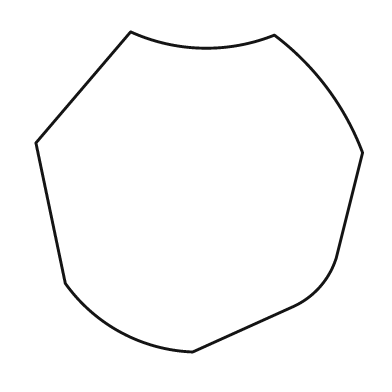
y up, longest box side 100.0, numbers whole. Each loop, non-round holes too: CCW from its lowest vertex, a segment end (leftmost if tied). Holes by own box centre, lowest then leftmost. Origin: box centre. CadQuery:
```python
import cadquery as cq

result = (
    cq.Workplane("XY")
    .moveTo(-2.0, -49.0)
    .lineTo(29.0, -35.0)
    .threePointArc((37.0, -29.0), (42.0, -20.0))
    .lineTo(50.0, 12.0)
    .threePointArc((39.0, 32.0), (23.0, 48.0))
    .threePointArc((1.0, 44.0), (-21.0, 49.0))
    .lineTo(-50.0, 15.0)
    .lineTo(-41.0, -28.0)
    .threePointArc((-24.0, -43.0), (-2.0, -49.0))
    .close()
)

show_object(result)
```